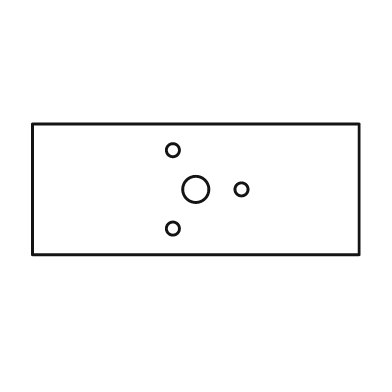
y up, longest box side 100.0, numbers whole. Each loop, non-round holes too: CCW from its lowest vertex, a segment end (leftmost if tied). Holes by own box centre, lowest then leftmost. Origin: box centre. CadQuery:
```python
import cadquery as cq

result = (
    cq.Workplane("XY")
    .moveTo(-50.0, -20.0)
    .lineTo(50.0, -20.0)
    .lineTo(50.0, 20.0)
    .lineTo(-50.0, 20.0)
    .close()
    .moveTo(-7.0, -12.0)
    .circle(2.0)
    .moveTo(0.0, 0.0)
    .circle(4.0)
    .moveTo(14.0, 0.0)
    .circle(2.0)
    .moveTo(-7.0, 12.0)
    .circle(2.0)
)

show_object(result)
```